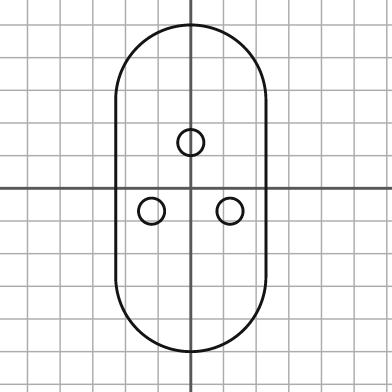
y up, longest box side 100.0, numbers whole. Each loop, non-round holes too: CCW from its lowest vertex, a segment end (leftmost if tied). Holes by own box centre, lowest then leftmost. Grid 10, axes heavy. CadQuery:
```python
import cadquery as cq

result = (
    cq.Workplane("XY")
    .moveTo(-23.0, -27.0)
    .threePointArc((0.0, -50.0), (23.0, -27.0))
    .lineTo(23.0, 27.0)
    .threePointArc((0.0, 50.0), (-23.0, 27.0))
    .close()
    .moveTo(-12.0, -7.0)
    .circle(4.0)
    .moveTo(12.0, -7.0)
    .circle(4.0)
    .moveTo(0.0, 14.0)
    .circle(4.0)
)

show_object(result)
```